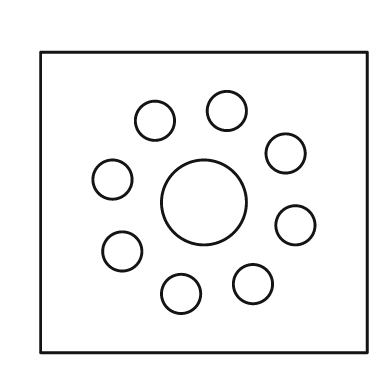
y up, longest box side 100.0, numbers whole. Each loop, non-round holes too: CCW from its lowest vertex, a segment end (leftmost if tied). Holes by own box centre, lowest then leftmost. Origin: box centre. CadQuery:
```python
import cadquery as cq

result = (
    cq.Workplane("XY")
    .moveTo(-50.0, -46.0)
    .lineTo(50.0, -46.0)
    .lineTo(50.0, 46.0)
    .lineTo(-50.0, 46.0)
    .close()
    .moveTo(-7.0, -28.0)
    .circle(6.0)
    .moveTo(15.0, -25.0)
    .circle(6.0)
    .moveTo(-25.0, -15.0)
    .circle(6.0)
    .moveTo(28.0, -7.0)
    .circle(6.0)
    .moveTo(0.0, 0.0)
    .circle(13.0)
    .moveTo(-28.0, 7.0)
    .circle(6.0)
    .moveTo(25.0, 15.0)
    .circle(6.0)
    .moveTo(-15.0, 25.0)
    .circle(6.0)
    .moveTo(7.0, 28.0)
    .circle(6.0)
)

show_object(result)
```